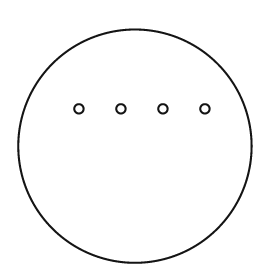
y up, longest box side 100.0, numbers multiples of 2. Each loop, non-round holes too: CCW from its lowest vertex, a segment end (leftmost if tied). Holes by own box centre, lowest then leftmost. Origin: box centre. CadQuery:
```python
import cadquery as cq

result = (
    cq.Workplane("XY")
    .moveTo(0.0, 0.0)
    .circle(50.0)
    .moveTo(-24.0, 16.0)
    .circle(2.0)
    .moveTo(-6.0, 16.0)
    .circle(2.0)
    .moveTo(12.0, 16.0)
    .circle(2.0)
    .moveTo(30.0, 16.0)
    .circle(2.0)
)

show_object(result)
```